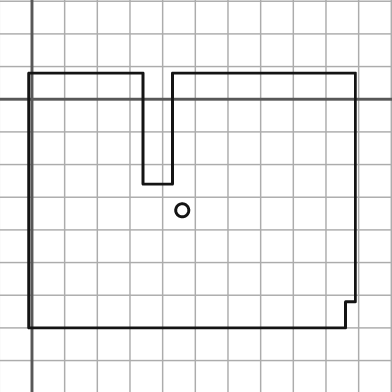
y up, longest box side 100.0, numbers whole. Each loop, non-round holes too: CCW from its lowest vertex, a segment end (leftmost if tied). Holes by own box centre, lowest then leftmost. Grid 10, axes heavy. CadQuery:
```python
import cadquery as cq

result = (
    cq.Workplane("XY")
    .moveTo(-1.0, -70.0)
    .lineTo(96.0, -70.0)
    .lineTo(96.0, -62.0)
    .lineTo(99.0, -62.0)
    .lineTo(99.0, 8.0)
    .lineTo(43.0, 8.0)
    .lineTo(43.0, -26.0)
    .lineTo(34.0, -26.0)
    .lineTo(34.0, 8.0)
    .lineTo(-1.0, 8.0)
    .close()
    .moveTo(46.0, -34.0)
    .circle(2.0)
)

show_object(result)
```